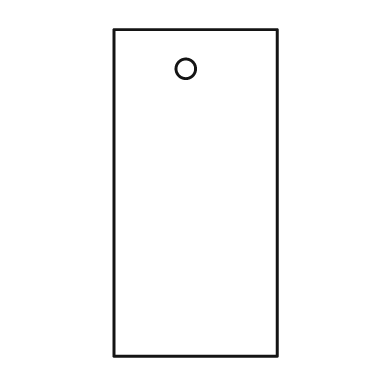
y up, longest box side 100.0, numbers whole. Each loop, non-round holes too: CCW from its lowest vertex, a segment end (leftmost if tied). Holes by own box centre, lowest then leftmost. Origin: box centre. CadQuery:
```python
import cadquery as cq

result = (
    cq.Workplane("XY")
    .moveTo(-25.0, -50.0)
    .lineTo(25.0, -50.0)
    .lineTo(25.0, 50.0)
    .lineTo(-25.0, 50.0)
    .close()
    .moveTo(-3.0, 38.0)
    .circle(3.0)
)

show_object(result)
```